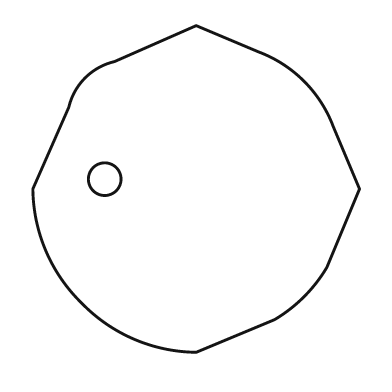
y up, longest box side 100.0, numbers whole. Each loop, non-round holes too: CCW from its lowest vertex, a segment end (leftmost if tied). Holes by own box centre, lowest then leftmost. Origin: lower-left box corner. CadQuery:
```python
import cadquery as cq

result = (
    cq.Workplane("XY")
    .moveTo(50.0, 0.0)
    .lineTo(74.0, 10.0)
    .threePointArc((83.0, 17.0), (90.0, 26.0))
    .lineTo(100.0, 50.0)
    .lineTo(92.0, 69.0)
    .threePointArc((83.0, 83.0), (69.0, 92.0))
    .lineTo(50.0, 100.0)
    .lineTo(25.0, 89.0)
    .threePointArc((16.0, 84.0), (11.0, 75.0))
    .lineTo(0.0, 50.0)
    .threePointArc((4.0, 31.0), (15.0, 15.0))
    .threePointArc((31.0, 4.0), (50.0, 0.0))
    .close()
    .moveTo(22.0, 53.0)
    .circle(5.0)
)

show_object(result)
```